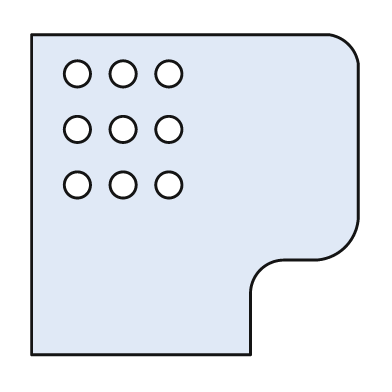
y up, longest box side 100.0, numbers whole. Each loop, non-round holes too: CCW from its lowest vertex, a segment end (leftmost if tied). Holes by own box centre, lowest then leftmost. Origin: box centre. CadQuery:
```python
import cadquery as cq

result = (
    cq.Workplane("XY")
    .moveTo(-50.0, -49.0)
    .lineTo(17.0, -49.0)
    .lineTo(17.0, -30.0)
    .threePointArc((20.0, -23.0), (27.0, -20.0))
    .lineTo(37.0, -20.0)
    .threePointArc((46.0, -16.0), (50.0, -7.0))
    .lineTo(50.0, 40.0)
    .threePointArc((47.0, 46.0), (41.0, 49.0))
    .lineTo(-50.0, 49.0)
    .close()
    .moveTo(-36.0, 3.0)
    .circle(4.0)
    .moveTo(-22.0, 3.0)
    .circle(4.0)
    .moveTo(-8.0, 3.0)
    .circle(4.0)
    .moveTo(-36.0, 20.0)
    .circle(4.0)
    .moveTo(-22.0, 20.0)
    .circle(4.0)
    .moveTo(-8.0, 20.0)
    .circle(4.0)
    .moveTo(-36.0, 37.0)
    .circle(4.0)
    .moveTo(-22.0, 37.0)
    .circle(4.0)
    .moveTo(-8.0, 37.0)
    .circle(4.0)
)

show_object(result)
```